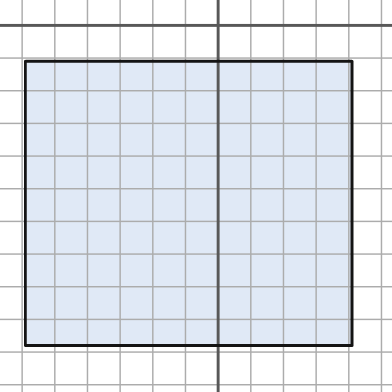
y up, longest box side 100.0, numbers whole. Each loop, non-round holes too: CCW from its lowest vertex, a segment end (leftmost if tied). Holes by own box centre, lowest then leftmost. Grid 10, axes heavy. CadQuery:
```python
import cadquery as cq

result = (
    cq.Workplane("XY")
    .moveTo(-59.0, -98.0)
    .lineTo(41.0, -98.0)
    .lineTo(41.0, -11.0)
    .lineTo(-59.0, -11.0)
    .close()
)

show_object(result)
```